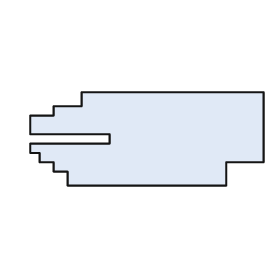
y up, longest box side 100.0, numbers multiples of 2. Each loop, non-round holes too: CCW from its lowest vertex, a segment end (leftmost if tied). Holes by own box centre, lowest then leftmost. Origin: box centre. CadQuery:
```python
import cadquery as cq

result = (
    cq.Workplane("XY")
    .moveTo(-34.0, -20.0)
    .lineTo(34.0, -20.0)
    .lineTo(34.0, -10.0)
    .lineTo(50.0, -10.0)
    .lineTo(50.0, 20.0)
    .lineTo(-28.0, 20.0)
    .lineTo(-28.0, 14.0)
    .lineTo(-40.0, 14.0)
    .lineTo(-40.0, 10.0)
    .lineTo(-50.0, 10.0)
    .lineTo(-50.0, 2.0)
    .lineTo(-16.0, 2.0)
    .lineTo(-16.0, -2.0)
    .lineTo(-50.0, -2.0)
    .lineTo(-50.0, -6.0)
    .lineTo(-46.0, -6.0)
    .lineTo(-46.0, -10.0)
    .lineTo(-40.0, -10.0)
    .lineTo(-40.0, -14.0)
    .lineTo(-34.0, -14.0)
    .close()
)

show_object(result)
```